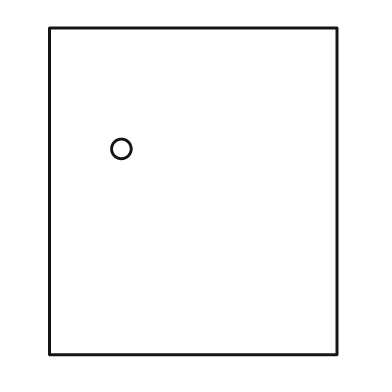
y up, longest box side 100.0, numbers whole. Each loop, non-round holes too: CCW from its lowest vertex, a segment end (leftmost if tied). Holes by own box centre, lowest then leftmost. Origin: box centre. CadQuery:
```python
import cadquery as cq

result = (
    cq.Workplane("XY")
    .moveTo(-44.0, -50.0)
    .lineTo(44.0, -50.0)
    .lineTo(44.0, 50.0)
    .lineTo(-44.0, 50.0)
    .close()
    .moveTo(-22.0, 13.0)
    .circle(3.0)
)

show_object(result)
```